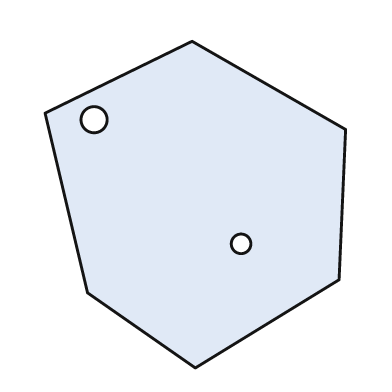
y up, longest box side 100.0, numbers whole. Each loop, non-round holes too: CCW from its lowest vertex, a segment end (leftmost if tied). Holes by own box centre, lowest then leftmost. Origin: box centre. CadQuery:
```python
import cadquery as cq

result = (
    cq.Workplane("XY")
    .moveTo(0.0, -50.0)
    .lineTo(44.0, -23.0)
    .lineTo(46.0, 23.0)
    .lineTo(-1.0, 50.0)
    .lineTo(-46.0, 28.0)
    .lineTo(-33.0, -27.0)
    .close()
    .moveTo(14.0, -12.0)
    .circle(3.0)
    .moveTo(-31.0, 26.0)
    .circle(4.0)
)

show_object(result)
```